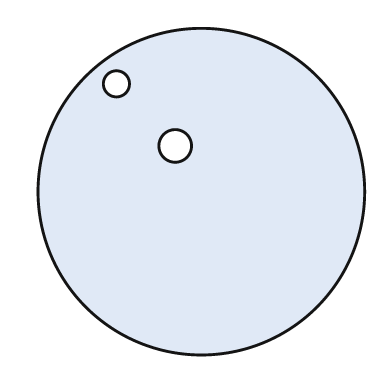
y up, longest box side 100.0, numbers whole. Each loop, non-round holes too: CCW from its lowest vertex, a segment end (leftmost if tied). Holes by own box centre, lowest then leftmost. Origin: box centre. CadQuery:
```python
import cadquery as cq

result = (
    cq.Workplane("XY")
    .moveTo(0.0, 0.0)
    .circle(50.0)
    .moveTo(-8.0, 14.0)
    .circle(5.0)
    .moveTo(-26.0, 33.0)
    .circle(4.0)
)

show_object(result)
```